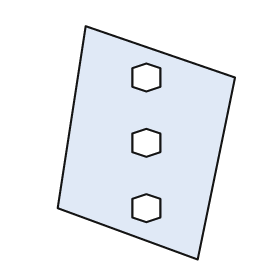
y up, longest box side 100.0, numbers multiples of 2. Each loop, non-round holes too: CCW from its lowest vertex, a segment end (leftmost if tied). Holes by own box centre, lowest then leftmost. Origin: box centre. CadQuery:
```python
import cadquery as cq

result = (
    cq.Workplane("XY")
    .moveTo(22.0, -50.0)
    .lineTo(38.0, 28.0)
    .lineTo(-26.0, 50.0)
    .lineTo(-38.0, -28.0)
    .close()
    .moveTo(0.0, -34.0)
    .lineTo(6.0, -32.0)
    .lineTo(6.0, -24.0)
    .lineTo(0.0, -22.0)
    .lineTo(-6.0, -24.0)
    .lineTo(-6.0, -32.0)
    .close()
    .moveTo(0.0, -6.0)
    .lineTo(6.0, -4.0)
    .lineTo(6.0, 4.0)
    .lineTo(0.0, 6.0)
    .lineTo(-6.0, 4.0)
    .lineTo(-6.0, -4.0)
    .close()
    .moveTo(0.0, 22.0)
    .lineTo(6.0, 24.0)
    .lineTo(6.0, 32.0)
    .lineTo(0.0, 34.0)
    .lineTo(-6.0, 32.0)
    .lineTo(-6.0, 24.0)
    .close()
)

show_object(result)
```